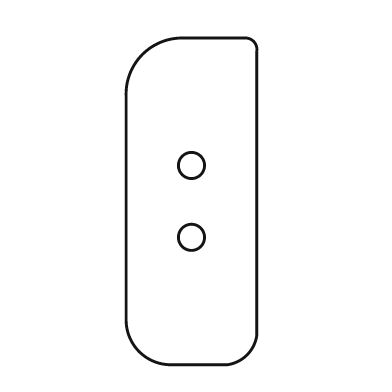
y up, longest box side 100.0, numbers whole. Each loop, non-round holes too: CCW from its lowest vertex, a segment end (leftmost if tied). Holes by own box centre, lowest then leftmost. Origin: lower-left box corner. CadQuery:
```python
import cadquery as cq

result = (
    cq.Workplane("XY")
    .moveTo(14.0, 0.0)
    .lineTo(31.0, 0.0)
    .threePointArc((37.0, 3.0), (40.0, 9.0))
    .lineTo(40.0, 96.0)
    .threePointArc((39.0, 99.0), (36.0, 100.0))
    .lineTo(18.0, 100.0)
    .threePointArc((5.0, 95.0), (0.0, 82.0))
    .lineTo(0.0, 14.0)
    .threePointArc((4.0, 4.0), (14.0, 0.0))
    .close()
    .moveTo(20.0, 39.0)
    .circle(4.0)
    .moveTo(20.0, 61.0)
    .circle(4.0)
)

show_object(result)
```